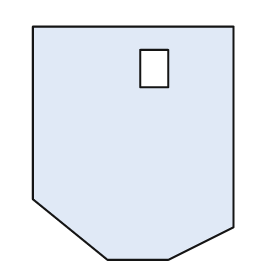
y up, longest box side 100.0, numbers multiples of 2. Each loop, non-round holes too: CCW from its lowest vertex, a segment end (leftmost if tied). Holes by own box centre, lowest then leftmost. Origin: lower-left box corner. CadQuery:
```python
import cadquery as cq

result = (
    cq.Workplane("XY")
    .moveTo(32.0, 0.0)
    .lineTo(58.0, 0.0)
    .lineTo(86.0, 14.0)
    .lineTo(86.0, 100.0)
    .lineTo(0.0, 100.0)
    .lineTo(0.0, 26.0)
    .close()
    .moveTo(46.0, 74.0)
    .lineTo(58.0, 74.0)
    .lineTo(58.0, 90.0)
    .lineTo(46.0, 90.0)
    .close()
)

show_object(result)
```